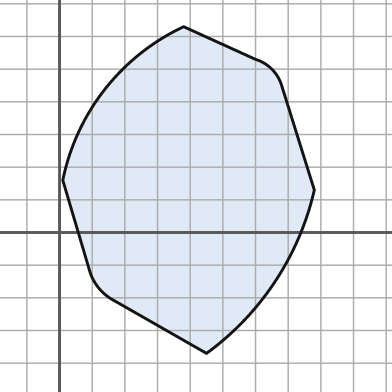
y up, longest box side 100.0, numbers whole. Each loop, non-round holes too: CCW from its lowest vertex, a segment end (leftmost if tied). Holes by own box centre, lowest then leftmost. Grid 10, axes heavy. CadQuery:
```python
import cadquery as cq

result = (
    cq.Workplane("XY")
    .moveTo(45.0, -37.0)
    .threePointArc((66.0, -15.0), (78.0, 13.0))
    .lineTo(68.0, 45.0)
    .threePointArc((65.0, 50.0), (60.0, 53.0))
    .lineTo(38.0, 63.0)
    .threePointArc((14.0, 44.0), (1.0, 16.0))
    .lineTo(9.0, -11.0)
    .threePointArc((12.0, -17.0), (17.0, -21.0))
    .close()
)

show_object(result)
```